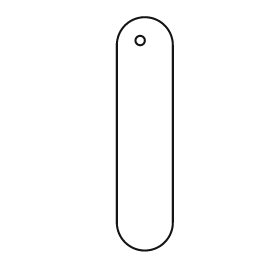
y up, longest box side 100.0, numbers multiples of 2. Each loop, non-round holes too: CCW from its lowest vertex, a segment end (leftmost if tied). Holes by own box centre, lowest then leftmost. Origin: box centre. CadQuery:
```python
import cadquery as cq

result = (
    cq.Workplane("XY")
    .moveTo(-12.0, -38.0)
    .threePointArc((0.0, -50.0), (12.0, -38.0))
    .lineTo(12.0, 38.0)
    .threePointArc((0.0, 50.0), (-12.0, 38.0))
    .close()
    .moveTo(-2.0, 40.0)
    .circle(2.0)
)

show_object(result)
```